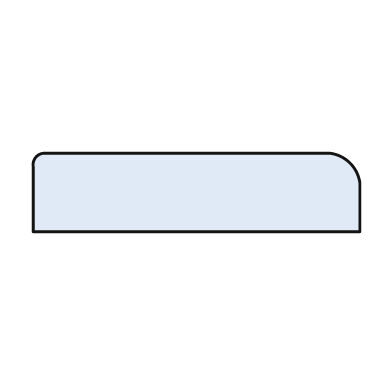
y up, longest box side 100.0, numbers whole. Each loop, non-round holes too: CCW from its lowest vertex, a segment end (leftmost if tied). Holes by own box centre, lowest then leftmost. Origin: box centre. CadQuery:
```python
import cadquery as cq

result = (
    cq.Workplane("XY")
    .moveTo(-50.0, -12.0)
    .lineTo(50.0, -12.0)
    .lineTo(50.0, 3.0)
    .threePointArc((47.0, 9.0), (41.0, 12.0))
    .lineTo(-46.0, 12.0)
    .threePointArc((-49.0, 11.0), (-50.0, 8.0))
    .close()
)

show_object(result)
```